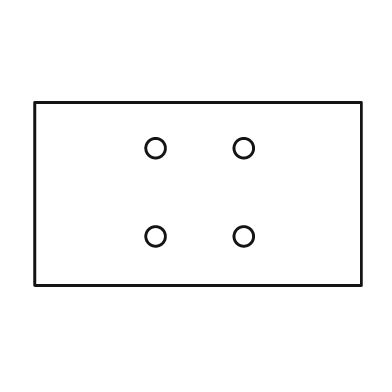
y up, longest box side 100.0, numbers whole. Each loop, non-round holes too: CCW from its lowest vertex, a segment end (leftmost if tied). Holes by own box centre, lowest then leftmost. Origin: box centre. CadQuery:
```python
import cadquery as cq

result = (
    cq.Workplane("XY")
    .moveTo(-50.0, -28.0)
    .lineTo(50.0, -28.0)
    .lineTo(50.0, 28.0)
    .lineTo(-50.0, 28.0)
    .close()
    .moveTo(-13.0, -13.0)
    .circle(3.0)
    .moveTo(14.0, -13.0)
    .circle(3.0)
    .moveTo(-13.0, 14.0)
    .circle(3.0)
    .moveTo(14.0, 14.0)
    .circle(3.0)
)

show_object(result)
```